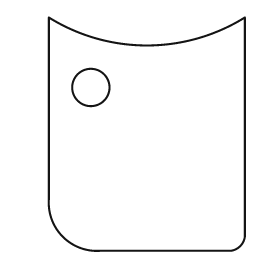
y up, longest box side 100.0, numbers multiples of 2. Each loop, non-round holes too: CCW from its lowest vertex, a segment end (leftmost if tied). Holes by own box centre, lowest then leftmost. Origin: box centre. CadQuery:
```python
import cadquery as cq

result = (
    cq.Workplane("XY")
    .moveTo(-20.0, -50.0)
    .lineTo(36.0, -50.0)
    .threePointArc((40.0, -48.0), (42.0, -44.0))
    .lineTo(42.0, 50.0)
    .threePointArc((0.0, 38.0), (-42.0, 50.0))
    .lineTo(-42.0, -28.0)
    .threePointArc((-36.0, -44.0), (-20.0, -50.0))
    .close()
    .moveTo(-24.0, 20.0)
    .circle(8.0)
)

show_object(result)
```